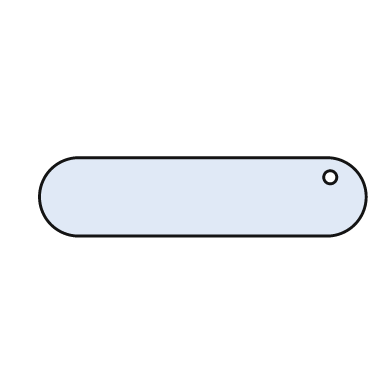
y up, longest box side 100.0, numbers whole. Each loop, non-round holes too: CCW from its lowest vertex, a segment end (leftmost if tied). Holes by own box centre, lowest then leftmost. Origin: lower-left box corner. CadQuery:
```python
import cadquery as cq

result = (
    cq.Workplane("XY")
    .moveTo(12.0, 0.0)
    .lineTo(88.0, 0.0)
    .threePointArc((100.0, 12.0), (88.0, 24.0))
    .lineTo(12.0, 24.0)
    .threePointArc((0.0, 12.0), (12.0, 0.0))
    .close()
    .moveTo(89.0, 18.0)
    .circle(2.0)
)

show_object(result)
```